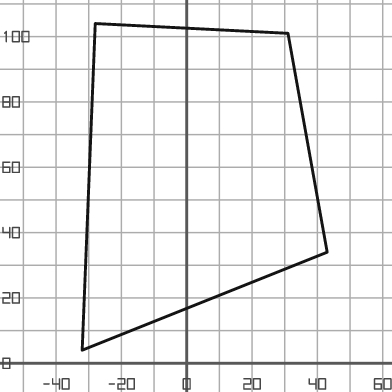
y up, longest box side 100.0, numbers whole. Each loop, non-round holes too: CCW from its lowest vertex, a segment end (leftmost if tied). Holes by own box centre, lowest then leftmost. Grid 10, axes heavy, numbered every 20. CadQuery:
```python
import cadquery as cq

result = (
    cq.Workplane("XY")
    .moveTo(-32.0, 4.0)
    .lineTo(43.0, 34.0)
    .lineTo(31.0, 101.0)
    .lineTo(-28.0, 104.0)
    .close()
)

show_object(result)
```